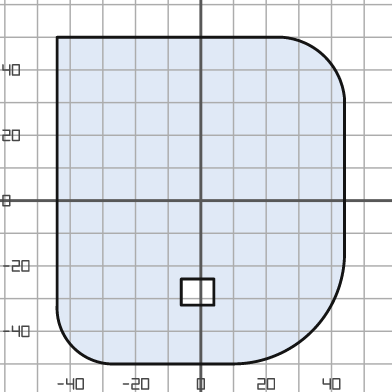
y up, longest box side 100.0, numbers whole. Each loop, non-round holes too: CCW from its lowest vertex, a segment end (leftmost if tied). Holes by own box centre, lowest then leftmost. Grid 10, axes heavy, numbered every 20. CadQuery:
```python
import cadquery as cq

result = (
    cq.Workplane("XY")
    .moveTo(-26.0, -50.0)
    .lineTo(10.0, -50.0)
    .threePointArc((34.0, -40.0), (44.0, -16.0))
    .lineTo(44.0, 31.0)
    .threePointArc((38.0, 44.0), (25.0, 50.0))
    .lineTo(-44.0, 50.0)
    .lineTo(-44.0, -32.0)
    .threePointArc((-39.0, -45.0), (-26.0, -50.0))
    .close()
    .moveTo(-6.0, -32.0)
    .lineTo(4.0, -32.0)
    .lineTo(4.0, -24.0)
    .lineTo(-6.0, -24.0)
    .close()
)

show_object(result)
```